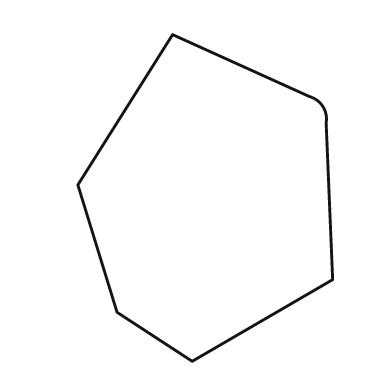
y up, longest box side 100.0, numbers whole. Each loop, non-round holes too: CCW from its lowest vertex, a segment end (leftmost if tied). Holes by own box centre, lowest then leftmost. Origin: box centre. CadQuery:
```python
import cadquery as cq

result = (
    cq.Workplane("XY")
    .moveTo(-4.0, -50.0)
    .lineTo(39.0, -25.0)
    .lineTo(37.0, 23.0)
    .threePointArc((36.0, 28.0), (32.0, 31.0))
    .lineTo(-10.0, 50.0)
    .lineTo(-39.0, 4.0)
    .lineTo(-27.0, -35.0)
    .close()
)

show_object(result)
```